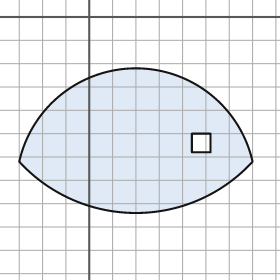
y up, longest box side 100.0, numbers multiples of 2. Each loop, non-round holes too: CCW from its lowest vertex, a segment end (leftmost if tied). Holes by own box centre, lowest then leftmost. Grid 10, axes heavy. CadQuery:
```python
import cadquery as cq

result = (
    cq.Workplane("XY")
    .moveTo(-30.0, -62.0)
    .threePointArc((20.0, -84.0), (70.0, -62.0))
    .threePointArc((20.0, -22.0), (-30.0, -62.0))
    .close()
    .moveTo(44.0, -58.0)
    .lineTo(52.0, -58.0)
    .lineTo(52.0, -50.0)
    .lineTo(44.0, -50.0)
    .close()
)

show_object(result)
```